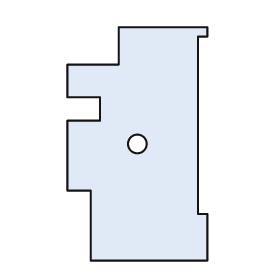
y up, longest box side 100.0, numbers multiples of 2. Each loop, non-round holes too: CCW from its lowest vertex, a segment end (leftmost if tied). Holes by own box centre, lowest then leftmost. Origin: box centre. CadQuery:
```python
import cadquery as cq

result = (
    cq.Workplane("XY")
    .moveTo(-20.0, -50.0)
    .lineTo(30.0, -50.0)
    .lineTo(30.0, -30.0)
    .lineTo(26.0, -30.0)
    .lineTo(26.0, 46.0)
    .lineTo(30.0, 46.0)
    .lineTo(30.0, 50.0)
    .lineTo(-8.0, 50.0)
    .lineTo(-8.0, 34.0)
    .lineTo(-30.0, 34.0)
    .lineTo(-30.0, 20.0)
    .lineTo(-16.0, 20.0)
    .lineTo(-16.0, 10.0)
    .lineTo(-30.0, 10.0)
    .lineTo(-30.0, -20.0)
    .lineTo(-20.0, -20.0)
    .close()
    .moveTo(0.0, 0.0)
    .circle(4.0)
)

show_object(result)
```